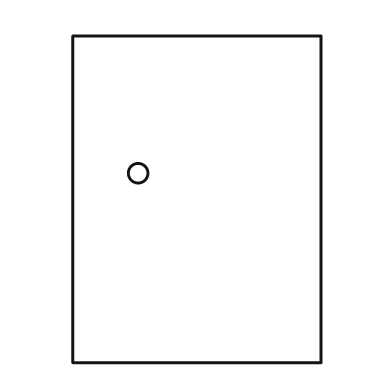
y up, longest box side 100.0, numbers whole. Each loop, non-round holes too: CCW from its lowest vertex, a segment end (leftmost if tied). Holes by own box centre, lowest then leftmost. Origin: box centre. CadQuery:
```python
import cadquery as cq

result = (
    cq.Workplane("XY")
    .moveTo(-38.0, -50.0)
    .lineTo(38.0, -50.0)
    .lineTo(38.0, 50.0)
    .lineTo(-38.0, 50.0)
    .close()
    .moveTo(-18.0, 8.0)
    .circle(3.0)
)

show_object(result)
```